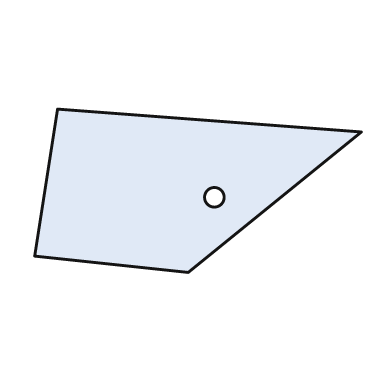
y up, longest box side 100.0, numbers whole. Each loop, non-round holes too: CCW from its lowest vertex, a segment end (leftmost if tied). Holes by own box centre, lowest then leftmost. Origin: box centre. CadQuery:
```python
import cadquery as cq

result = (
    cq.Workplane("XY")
    .moveTo(-3.0, -25.0)
    .lineTo(50.0, 18.0)
    .lineTo(-43.0, 25.0)
    .lineTo(-50.0, -20.0)
    .close()
    .moveTo(5.0, -2.0)
    .circle(3.0)
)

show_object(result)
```